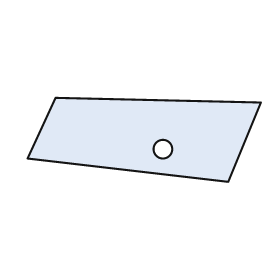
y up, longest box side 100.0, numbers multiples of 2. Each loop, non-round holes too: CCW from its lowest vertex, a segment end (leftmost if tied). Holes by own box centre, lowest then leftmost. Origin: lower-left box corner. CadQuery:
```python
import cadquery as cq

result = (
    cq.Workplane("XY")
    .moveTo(86.0, 0.0)
    .lineTo(100.0, 34.0)
    .lineTo(12.0, 36.0)
    .lineTo(0.0, 10.0)
    .close()
    .moveTo(58.0, 14.0)
    .circle(4.0)
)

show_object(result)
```